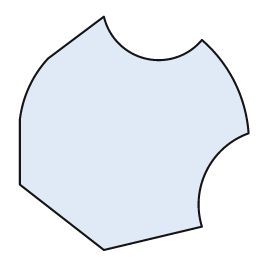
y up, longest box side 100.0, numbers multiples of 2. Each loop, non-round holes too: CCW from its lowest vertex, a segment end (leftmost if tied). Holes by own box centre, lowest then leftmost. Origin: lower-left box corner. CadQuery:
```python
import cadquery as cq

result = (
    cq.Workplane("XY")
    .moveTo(36.0, 0.0)
    .lineTo(78.0, 10.0)
    .threePointArc((80.0, 34.0), (98.0, 50.0))
    .threePointArc((92.0, 72.0), (78.0, 90.0))
    .threePointArc((54.0, 82.0), (36.0, 100.0))
    .lineTo(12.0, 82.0)
    .threePointArc((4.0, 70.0), (0.0, 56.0))
    .lineTo(0.0, 28.0)
    .close()
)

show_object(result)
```